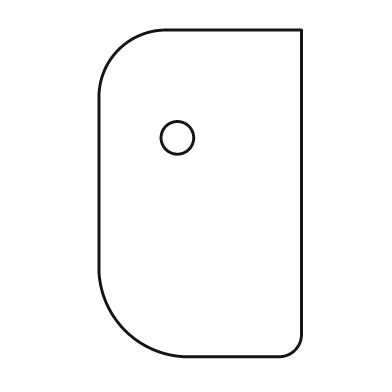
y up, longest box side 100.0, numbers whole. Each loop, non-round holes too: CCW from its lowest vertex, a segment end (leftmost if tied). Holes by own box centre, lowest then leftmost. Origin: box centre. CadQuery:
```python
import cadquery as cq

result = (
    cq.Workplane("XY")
    .moveTo(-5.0, -50.0)
    .lineTo(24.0, -50.0)
    .threePointArc((29.0, -48.0), (31.0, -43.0))
    .lineTo(31.0, 50.0)
    .lineTo(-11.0, 50.0)
    .threePointArc((-25.0, 44.0), (-31.0, 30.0))
    .lineTo(-31.0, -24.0)
    .threePointArc((-23.0, -42.0), (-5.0, -50.0))
    .close()
    .moveTo(-7.0, 17.0)
    .circle(5.0)
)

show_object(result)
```